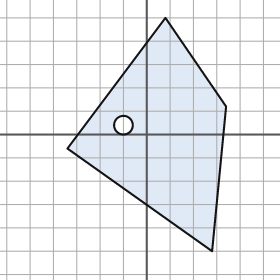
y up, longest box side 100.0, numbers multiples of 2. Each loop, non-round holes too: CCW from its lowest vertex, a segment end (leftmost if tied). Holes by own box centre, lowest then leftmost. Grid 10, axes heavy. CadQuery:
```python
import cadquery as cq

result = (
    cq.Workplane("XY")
    .moveTo(28.0, -50.0)
    .lineTo(34.0, 12.0)
    .lineTo(8.0, 50.0)
    .lineTo(-34.0, -6.0)
    .close()
    .moveTo(-10.0, 4.0)
    .circle(4.0)
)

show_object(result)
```